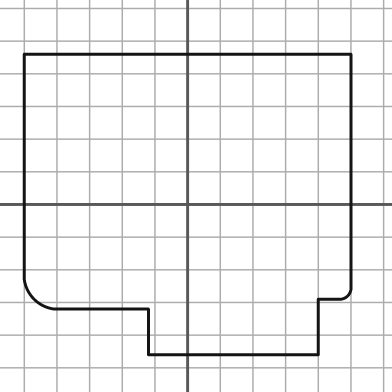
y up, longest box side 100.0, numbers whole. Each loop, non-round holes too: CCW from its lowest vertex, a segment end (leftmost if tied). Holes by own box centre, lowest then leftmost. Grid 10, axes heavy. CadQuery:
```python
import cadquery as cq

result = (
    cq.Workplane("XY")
    .moveTo(-12.0, -46.0)
    .lineTo(40.0, -46.0)
    .lineTo(40.0, -29.0)
    .lineTo(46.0, -29.0)
    .threePointArc((49.0, -28.0), (50.0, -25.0))
    .lineTo(50.0, 46.0)
    .lineTo(-50.0, 46.0)
    .lineTo(-50.0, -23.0)
    .threePointArc((-47.0, -29.0), (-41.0, -32.0))
    .lineTo(-12.0, -32.0)
    .close()
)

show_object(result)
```